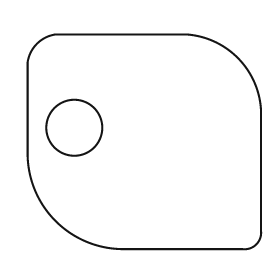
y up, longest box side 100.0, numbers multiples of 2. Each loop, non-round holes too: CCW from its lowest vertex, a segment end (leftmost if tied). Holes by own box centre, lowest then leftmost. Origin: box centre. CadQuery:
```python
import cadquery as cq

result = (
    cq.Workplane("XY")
    .moveTo(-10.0, -46.0)
    .lineTo(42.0, -46.0)
    .threePointArc((48.0, -44.0), (50.0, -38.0))
    .lineTo(50.0, 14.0)
    .threePointArc((40.0, 36.0), (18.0, 46.0))
    .lineTo(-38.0, 46.0)
    .threePointArc((-46.0, 42.0), (-50.0, 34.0))
    .lineTo(-50.0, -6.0)
    .threePointArc((-38.0, -34.0), (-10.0, -46.0))
    .close()
    .moveTo(-30.0, 6.0)
    .circle(12.0)
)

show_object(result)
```